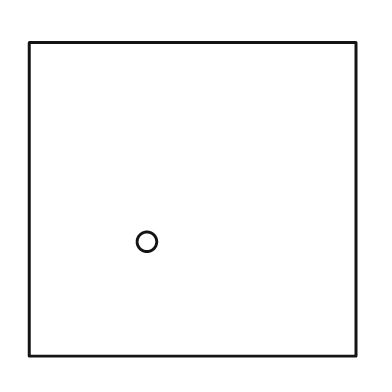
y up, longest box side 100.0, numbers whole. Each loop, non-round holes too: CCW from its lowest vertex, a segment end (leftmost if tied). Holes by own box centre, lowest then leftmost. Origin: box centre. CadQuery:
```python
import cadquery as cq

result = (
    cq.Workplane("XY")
    .moveTo(-50.0, -48.0)
    .lineTo(50.0, -48.0)
    .lineTo(50.0, 48.0)
    .lineTo(-50.0, 48.0)
    .close()
    .moveTo(-14.0, -13.0)
    .circle(3.0)
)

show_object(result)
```